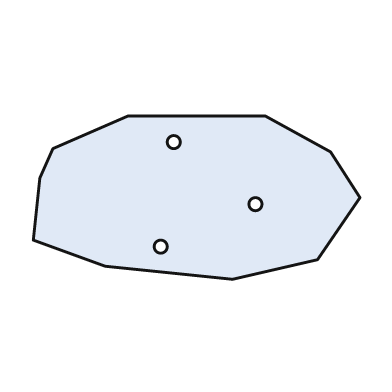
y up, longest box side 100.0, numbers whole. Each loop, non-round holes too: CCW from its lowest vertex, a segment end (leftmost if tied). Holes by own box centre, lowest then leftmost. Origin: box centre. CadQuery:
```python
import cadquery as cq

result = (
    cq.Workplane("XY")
    .moveTo(11.0, -25.0)
    .lineTo(37.0, -19.0)
    .lineTo(50.0, 0.0)
    .lineTo(41.0, 14.0)
    .lineTo(21.0, 25.0)
    .lineTo(-21.0, 25.0)
    .lineTo(-44.0, 15.0)
    .lineTo(-48.0, 6.0)
    .lineTo(-50.0, -13.0)
    .lineTo(-28.0, -21.0)
    .close()
    .moveTo(-11.0, -15.0)
    .circle(2.0)
    .moveTo(18.0, -2.0)
    .circle(2.0)
    .moveTo(-7.0, 17.0)
    .circle(2.0)
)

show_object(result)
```